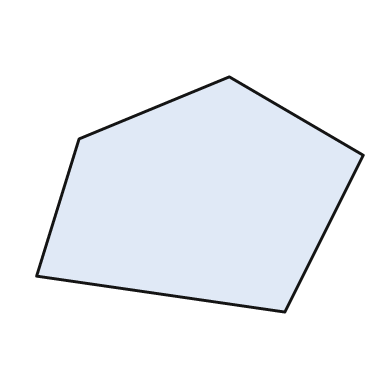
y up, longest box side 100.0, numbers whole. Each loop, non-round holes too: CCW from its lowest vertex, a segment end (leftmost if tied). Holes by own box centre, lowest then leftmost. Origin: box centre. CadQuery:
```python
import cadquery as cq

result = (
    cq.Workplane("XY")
    .moveTo(26.0, -36.0)
    .lineTo(50.0, 12.0)
    .lineTo(9.0, 36.0)
    .lineTo(-37.0, 17.0)
    .lineTo(-50.0, -25.0)
    .close()
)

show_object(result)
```